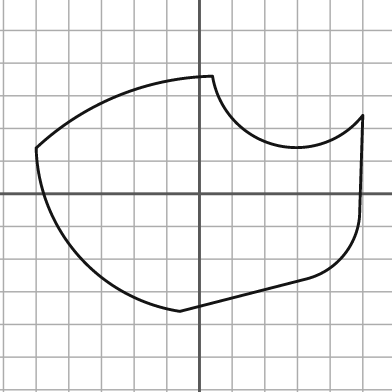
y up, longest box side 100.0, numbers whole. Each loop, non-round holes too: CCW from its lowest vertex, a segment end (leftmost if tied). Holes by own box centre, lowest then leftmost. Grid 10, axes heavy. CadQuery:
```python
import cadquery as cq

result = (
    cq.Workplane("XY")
    .moveTo(-6.0, -36.0)
    .lineTo(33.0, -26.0)
    .threePointArc((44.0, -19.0), (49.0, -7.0))
    .lineTo(50.0, 24.0)
    .threePointArc((23.0, 15.0), (4.0, 36.0))
    .threePointArc((-25.0, 30.0), (-50.0, 14.0))
    .threePointArc((-37.0, -19.0), (-6.0, -36.0))
    .close()
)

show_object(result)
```